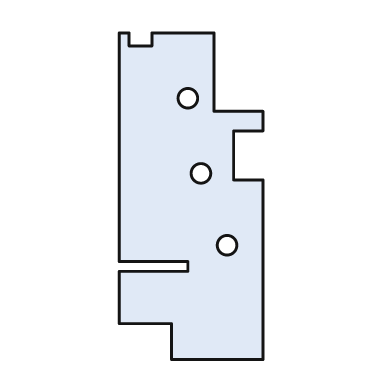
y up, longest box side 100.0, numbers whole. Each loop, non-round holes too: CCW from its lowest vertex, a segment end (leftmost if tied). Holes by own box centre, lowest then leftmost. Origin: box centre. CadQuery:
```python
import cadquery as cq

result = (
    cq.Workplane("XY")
    .moveTo(-6.0, -50.0)
    .lineTo(22.0, -50.0)
    .lineTo(22.0, 5.0)
    .lineTo(13.0, 5.0)
    .lineTo(13.0, 20.0)
    .lineTo(22.0, 20.0)
    .lineTo(22.0, 26.0)
    .lineTo(7.0, 26.0)
    .lineTo(7.0, 50.0)
    .lineTo(-12.0, 50.0)
    .lineTo(-12.0, 46.0)
    .lineTo(-19.0, 46.0)
    .lineTo(-19.0, 50.0)
    .lineTo(-22.0, 50.0)
    .lineTo(-22.0, -20.0)
    .lineTo(-1.0, -20.0)
    .lineTo(-1.0, -23.0)
    .lineTo(-22.0, -23.0)
    .lineTo(-22.0, -39.0)
    .lineTo(-6.0, -39.0)
    .close()
    .moveTo(11.0, -15.0)
    .circle(3.0)
    .moveTo(3.0, 7.0)
    .circle(3.0)
    .moveTo(-1.0, 30.0)
    .circle(3.0)
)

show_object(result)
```